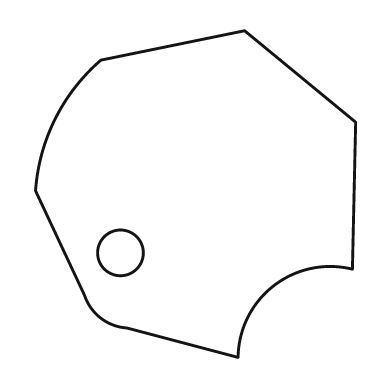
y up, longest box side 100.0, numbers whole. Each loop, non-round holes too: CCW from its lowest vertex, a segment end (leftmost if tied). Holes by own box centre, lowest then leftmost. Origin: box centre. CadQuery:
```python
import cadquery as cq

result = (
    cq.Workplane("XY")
    .moveTo(13.0, -50.0)
    .threePointArc((24.0, -28.0), (48.0, -23.0))
    .lineTo(49.0, 22.0)
    .lineTo(15.0, 50.0)
    .lineTo(-29.0, 41.0)
    .threePointArc((-43.0, 23.0), (-49.0, 1.0))
    .lineTo(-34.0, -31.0)
    .threePointArc((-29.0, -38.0), (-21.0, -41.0))
    .close()
    .moveTo(-23.0, -18.0)
    .circle(7.0)
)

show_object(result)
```